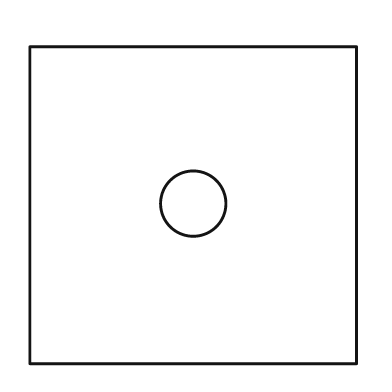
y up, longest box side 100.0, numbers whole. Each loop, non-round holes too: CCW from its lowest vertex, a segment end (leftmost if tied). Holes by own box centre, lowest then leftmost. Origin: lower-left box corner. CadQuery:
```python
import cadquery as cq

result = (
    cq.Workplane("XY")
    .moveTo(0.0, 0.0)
    .lineTo(100.0, 0.0)
    .lineTo(100.0, 97.0)
    .lineTo(0.0, 97.0)
    .close()
    .moveTo(50.0, 49.0)
    .circle(10.0)
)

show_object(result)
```